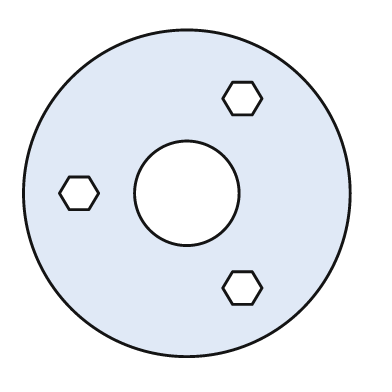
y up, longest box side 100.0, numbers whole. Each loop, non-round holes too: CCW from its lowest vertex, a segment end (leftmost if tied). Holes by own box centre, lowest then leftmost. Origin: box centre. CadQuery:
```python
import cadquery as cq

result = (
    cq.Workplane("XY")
    .moveTo(0.0, 0.0)
    .circle(50.0)
    .moveTo(14.0, -34.0)
    .lineTo(20.0, -34.0)
    .lineTo(23.0, -29.0)
    .lineTo(20.0, -24.0)
    .lineTo(14.0, -24.0)
    .lineTo(11.0, -29.0)
    .close()
    .moveTo(-36.0, -5.0)
    .lineTo(-30.0, -5.0)
    .lineTo(-27.0, 0.0)
    .lineTo(-30.0, 5.0)
    .lineTo(-36.0, 5.0)
    .lineTo(-39.0, 0.0)
    .close()
    .moveTo(0.0, 0.0)
    .circle(16.0)
    .moveTo(14.0, 24.0)
    .lineTo(20.0, 24.0)
    .lineTo(23.0, 29.0)
    .lineTo(20.0, 34.0)
    .lineTo(14.0, 34.0)
    .lineTo(11.0, 29.0)
    .close()
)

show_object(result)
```